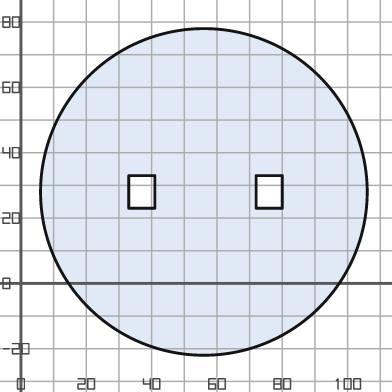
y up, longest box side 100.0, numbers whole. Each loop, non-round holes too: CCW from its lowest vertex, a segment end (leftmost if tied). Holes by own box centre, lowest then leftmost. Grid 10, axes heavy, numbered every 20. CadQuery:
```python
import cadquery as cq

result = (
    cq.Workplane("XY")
    .moveTo(56.0, 28.0)
    .circle(50.0)
    .moveTo(33.0, 23.0)
    .lineTo(41.0, 23.0)
    .lineTo(41.0, 33.0)
    .lineTo(33.0, 33.0)
    .close()
    .moveTo(72.0, 23.0)
    .lineTo(80.0, 23.0)
    .lineTo(80.0, 33.0)
    .lineTo(72.0, 33.0)
    .close()
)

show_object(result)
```